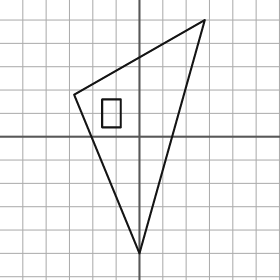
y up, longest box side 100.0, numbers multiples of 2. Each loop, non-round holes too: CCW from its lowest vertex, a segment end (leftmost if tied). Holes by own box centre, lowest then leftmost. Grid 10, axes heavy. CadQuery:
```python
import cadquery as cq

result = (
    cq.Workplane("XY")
    .moveTo(0.0, -50.0)
    .lineTo(28.0, 50.0)
    .lineTo(-28.0, 18.0)
    .close()
    .moveTo(-16.0, 4.0)
    .lineTo(-8.0, 4.0)
    .lineTo(-8.0, 16.0)
    .lineTo(-16.0, 16.0)
    .close()
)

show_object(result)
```